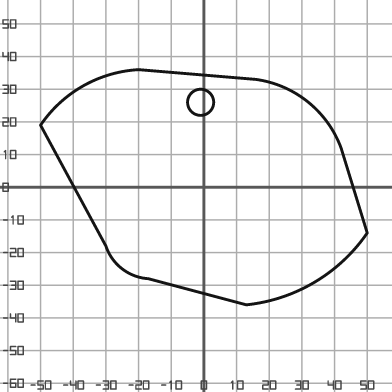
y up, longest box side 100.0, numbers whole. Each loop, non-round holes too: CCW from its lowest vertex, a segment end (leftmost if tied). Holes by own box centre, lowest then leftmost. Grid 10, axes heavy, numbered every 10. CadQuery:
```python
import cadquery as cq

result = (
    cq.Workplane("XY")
    .moveTo(13.0, -36.0)
    .threePointArc((34.0, -29.0), (50.0, -14.0))
    .lineTo(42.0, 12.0)
    .threePointArc((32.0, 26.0), (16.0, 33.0))
    .lineTo(-20.0, 36.0)
    .threePointArc((-37.0, 31.0), (-50.0, 19.0))
    .lineTo(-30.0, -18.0)
    .threePointArc((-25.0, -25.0), (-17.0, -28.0))
    .close()
    .moveTo(-1.0, 26.0)
    .circle(4.0)
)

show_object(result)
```